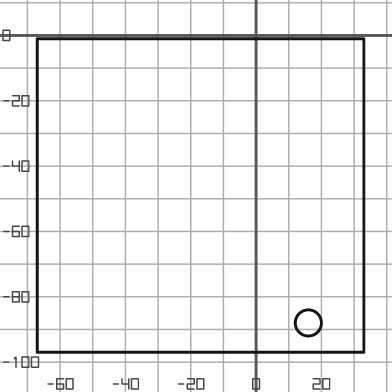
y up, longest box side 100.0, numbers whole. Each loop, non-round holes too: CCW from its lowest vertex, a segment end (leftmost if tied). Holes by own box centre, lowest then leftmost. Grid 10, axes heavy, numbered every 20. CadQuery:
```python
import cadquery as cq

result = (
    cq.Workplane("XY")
    .moveTo(-67.0, -97.0)
    .lineTo(33.0, -97.0)
    .lineTo(33.0, -1.0)
    .lineTo(-67.0, -1.0)
    .close()
    .moveTo(16.0, -88.0)
    .circle(4.0)
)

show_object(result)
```